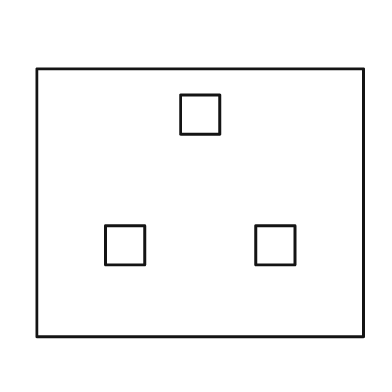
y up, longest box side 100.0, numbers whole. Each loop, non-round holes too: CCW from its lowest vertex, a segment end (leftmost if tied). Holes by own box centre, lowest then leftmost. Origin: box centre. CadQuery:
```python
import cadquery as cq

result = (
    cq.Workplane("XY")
    .moveTo(-50.0, -41.0)
    .lineTo(50.0, -41.0)
    .lineTo(50.0, 41.0)
    .lineTo(-50.0, 41.0)
    .close()
    .moveTo(-29.0, -19.0)
    .lineTo(-17.0, -19.0)
    .lineTo(-17.0, -7.0)
    .lineTo(-29.0, -7.0)
    .close()
    .moveTo(17.0, -19.0)
    .lineTo(29.0, -19.0)
    .lineTo(29.0, -7.0)
    .lineTo(17.0, -7.0)
    .close()
    .moveTo(-6.0, 21.0)
    .lineTo(6.0, 21.0)
    .lineTo(6.0, 33.0)
    .lineTo(-6.0, 33.0)
    .close()
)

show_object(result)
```